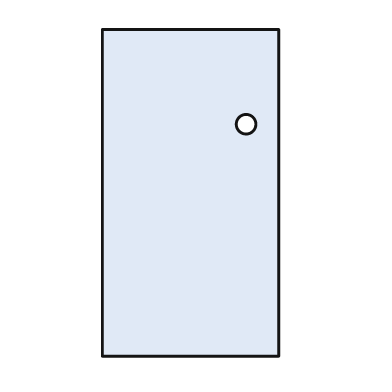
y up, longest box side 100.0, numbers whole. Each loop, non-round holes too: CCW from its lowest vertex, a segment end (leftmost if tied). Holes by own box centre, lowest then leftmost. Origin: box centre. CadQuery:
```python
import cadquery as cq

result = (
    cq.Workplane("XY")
    .moveTo(-27.0, -50.0)
    .lineTo(27.0, -50.0)
    .lineTo(27.0, 50.0)
    .lineTo(-27.0, 50.0)
    .close()
    .moveTo(17.0, 21.0)
    .circle(3.0)
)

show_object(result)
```